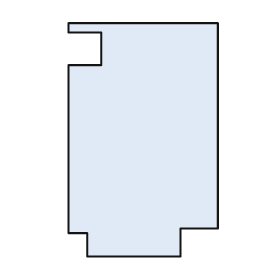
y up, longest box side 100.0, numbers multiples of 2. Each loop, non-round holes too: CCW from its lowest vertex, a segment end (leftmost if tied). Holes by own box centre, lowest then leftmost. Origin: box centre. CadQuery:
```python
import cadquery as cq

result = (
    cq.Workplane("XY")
    .moveTo(-24.0, -50.0)
    .lineTo(16.0, -50.0)
    .lineTo(16.0, -38.0)
    .lineTo(32.0, -38.0)
    .lineTo(32.0, 50.0)
    .lineTo(-32.0, 50.0)
    .lineTo(-32.0, 46.0)
    .lineTo(-18.0, 46.0)
    .lineTo(-18.0, 32.0)
    .lineTo(-32.0, 32.0)
    .lineTo(-32.0, -40.0)
    .lineTo(-24.0, -40.0)
    .close()
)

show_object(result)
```